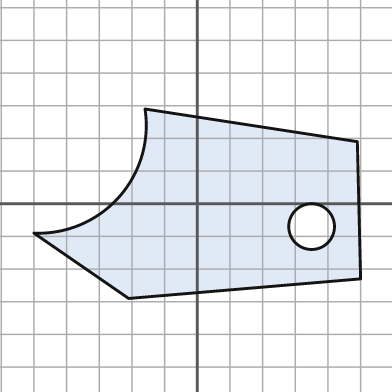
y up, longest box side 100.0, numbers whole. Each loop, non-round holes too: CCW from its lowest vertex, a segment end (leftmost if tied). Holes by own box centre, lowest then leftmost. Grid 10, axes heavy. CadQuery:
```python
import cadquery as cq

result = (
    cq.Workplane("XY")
    .moveTo(-21.0, -29.0)
    .lineTo(50.0, -23.0)
    .lineTo(49.0, 19.0)
    .lineTo(-16.0, 29.0)
    .threePointArc((-24.0, 2.0), (-50.0, -9.0))
    .close()
    .moveTo(35.0, -7.0)
    .circle(7.0)
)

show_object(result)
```